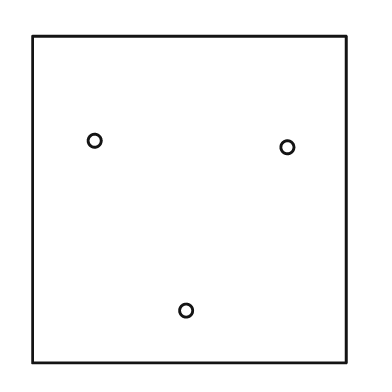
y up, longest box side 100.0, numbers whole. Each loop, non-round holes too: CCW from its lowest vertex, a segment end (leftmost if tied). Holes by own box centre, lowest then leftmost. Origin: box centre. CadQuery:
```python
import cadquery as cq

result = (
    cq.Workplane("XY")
    .moveTo(-48.0, -50.0)
    .lineTo(48.0, -50.0)
    .lineTo(48.0, 50.0)
    .lineTo(-48.0, 50.0)
    .close()
    .moveTo(-1.0, -34.0)
    .circle(2.0)
    .moveTo(30.0, 16.0)
    .circle(2.0)
    .moveTo(-29.0, 18.0)
    .circle(2.0)
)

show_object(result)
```